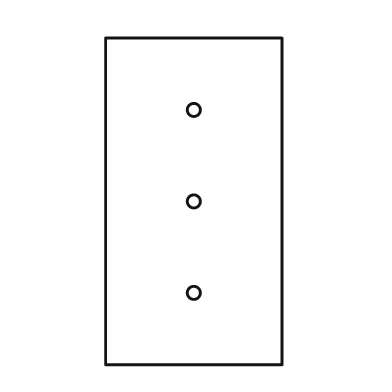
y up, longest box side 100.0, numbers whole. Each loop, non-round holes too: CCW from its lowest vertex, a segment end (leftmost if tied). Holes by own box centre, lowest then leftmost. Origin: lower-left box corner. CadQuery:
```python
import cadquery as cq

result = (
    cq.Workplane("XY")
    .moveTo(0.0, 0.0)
    .lineTo(54.0, 0.0)
    .lineTo(54.0, 100.0)
    .lineTo(0.0, 100.0)
    .close()
    .moveTo(27.0, 22.0)
    .circle(2.0)
    .moveTo(27.0, 50.0)
    .circle(2.0)
    .moveTo(27.0, 78.0)
    .circle(2.0)
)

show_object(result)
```